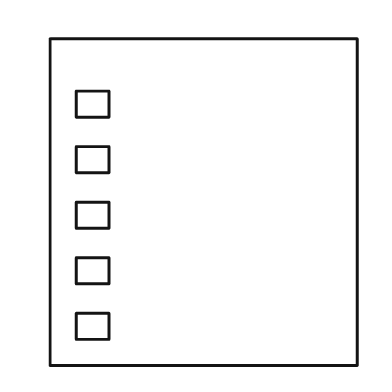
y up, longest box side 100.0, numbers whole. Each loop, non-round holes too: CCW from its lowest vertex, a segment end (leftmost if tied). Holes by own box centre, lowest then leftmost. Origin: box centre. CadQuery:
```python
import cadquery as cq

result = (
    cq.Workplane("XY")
    .moveTo(-47.0, -50.0)
    .lineTo(47.0, -50.0)
    .lineTo(47.0, 50.0)
    .lineTo(-47.0, 50.0)
    .close()
    .moveTo(-39.0, -42.0)
    .lineTo(-29.0, -42.0)
    .lineTo(-29.0, -34.0)
    .lineTo(-39.0, -34.0)
    .close()
    .moveTo(-39.0, -25.0)
    .lineTo(-29.0, -25.0)
    .lineTo(-29.0, -17.0)
    .lineTo(-39.0, -17.0)
    .close()
    .moveTo(-39.0, -8.0)
    .lineTo(-29.0, -8.0)
    .lineTo(-29.0, 0.0)
    .lineTo(-39.0, 0.0)
    .close()
    .moveTo(-39.0, 9.0)
    .lineTo(-29.0, 9.0)
    .lineTo(-29.0, 17.0)
    .lineTo(-39.0, 17.0)
    .close()
    .moveTo(-39.0, 26.0)
    .lineTo(-29.0, 26.0)
    .lineTo(-29.0, 34.0)
    .lineTo(-39.0, 34.0)
    .close()
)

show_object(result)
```